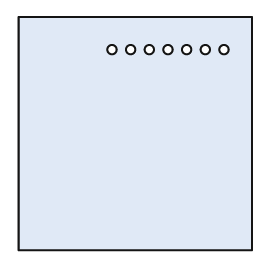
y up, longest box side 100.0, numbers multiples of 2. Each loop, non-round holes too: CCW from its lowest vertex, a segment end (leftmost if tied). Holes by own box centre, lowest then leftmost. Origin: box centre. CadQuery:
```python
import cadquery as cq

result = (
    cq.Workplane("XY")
    .moveTo(-50.0, -50.0)
    .lineTo(50.0, -50.0)
    .lineTo(50.0, 50.0)
    .lineTo(-50.0, 50.0)
    .close()
    .moveTo(-10.0, 36.0)
    .circle(2.0)
    .moveTo(-2.0, 36.0)
    .circle(2.0)
    .moveTo(6.0, 36.0)
    .circle(2.0)
    .moveTo(14.0, 36.0)
    .circle(2.0)
    .moveTo(22.0, 36.0)
    .circle(2.0)
    .moveTo(30.0, 36.0)
    .circle(2.0)
    .moveTo(38.0, 36.0)
    .circle(2.0)
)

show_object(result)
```